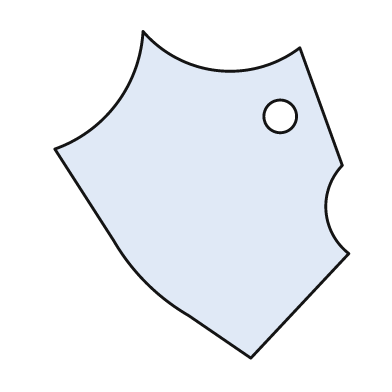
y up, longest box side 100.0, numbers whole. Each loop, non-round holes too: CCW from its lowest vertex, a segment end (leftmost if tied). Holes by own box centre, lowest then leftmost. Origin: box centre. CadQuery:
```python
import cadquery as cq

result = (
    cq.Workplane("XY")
    .moveTo(15.0, -50.0)
    .lineTo(45.0, -18.0)
    .threePointArc((38.0, -5.0), (43.0, 9.0))
    .lineTo(30.0, 45.0)
    .threePointArc((5.0, 38.0), (-18.0, 50.0))
    .threePointArc((-26.0, 28.0), (-45.0, 14.0))
    .lineTo(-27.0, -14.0)
    .threePointArc((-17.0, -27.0), (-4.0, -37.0))
    .close()
    .moveTo(24.0, 24.0)
    .circle(5.0)
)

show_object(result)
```